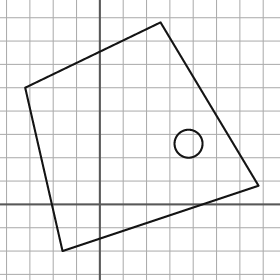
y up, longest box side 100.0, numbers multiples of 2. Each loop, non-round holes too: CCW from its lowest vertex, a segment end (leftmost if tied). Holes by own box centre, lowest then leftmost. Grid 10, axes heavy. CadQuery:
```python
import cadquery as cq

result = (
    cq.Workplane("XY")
    .moveTo(-16.0, -20.0)
    .lineTo(68.0, 8.0)
    .lineTo(26.0, 78.0)
    .lineTo(-32.0, 50.0)
    .close()
    .moveTo(38.0, 26.0)
    .circle(6.0)
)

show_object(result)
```